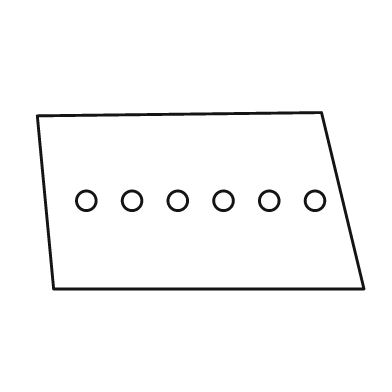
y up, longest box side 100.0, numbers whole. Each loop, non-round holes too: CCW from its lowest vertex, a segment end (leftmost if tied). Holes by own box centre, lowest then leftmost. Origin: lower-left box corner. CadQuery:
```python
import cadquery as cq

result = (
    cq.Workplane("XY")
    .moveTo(5.0, 0.0)
    .lineTo(100.0, 0.0)
    .lineTo(87.0, 54.0)
    .lineTo(0.0, 53.0)
    .close()
    .moveTo(15.0, 27.0)
    .circle(3.0)
    .moveTo(29.0, 27.0)
    .circle(3.0)
    .moveTo(43.0, 27.0)
    .circle(3.0)
    .moveTo(57.0, 27.0)
    .circle(3.0)
    .moveTo(71.0, 27.0)
    .circle(3.0)
    .moveTo(85.0, 27.0)
    .circle(3.0)
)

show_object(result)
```